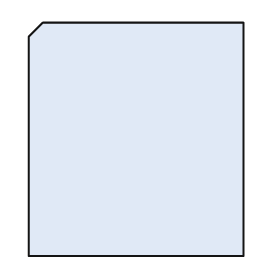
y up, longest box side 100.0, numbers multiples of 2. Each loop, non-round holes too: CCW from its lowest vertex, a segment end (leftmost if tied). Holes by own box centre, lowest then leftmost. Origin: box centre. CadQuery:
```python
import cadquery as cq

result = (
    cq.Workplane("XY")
    .moveTo(-46.0, -50.0)
    .lineTo(46.0, -50.0)
    .lineTo(46.0, 50.0)
    .lineTo(-40.0, 50.0)
    .lineTo(-46.0, 44.0)
    .close()
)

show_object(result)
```